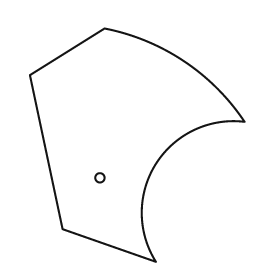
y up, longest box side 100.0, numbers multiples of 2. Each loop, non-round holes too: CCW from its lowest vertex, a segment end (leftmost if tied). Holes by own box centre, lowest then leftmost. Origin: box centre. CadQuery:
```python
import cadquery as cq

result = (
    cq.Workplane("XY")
    .moveTo(8.0, -50.0)
    .threePointArc((8.0, -8.0), (46.0, 10.0))
    .threePointArc((20.0, 36.0), (-14.0, 50.0))
    .lineTo(-46.0, 30.0)
    .lineTo(-32.0, -36.0)
    .close()
    .moveTo(-16.0, -14.0)
    .circle(2.0)
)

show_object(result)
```